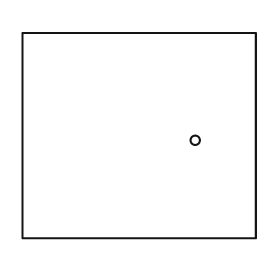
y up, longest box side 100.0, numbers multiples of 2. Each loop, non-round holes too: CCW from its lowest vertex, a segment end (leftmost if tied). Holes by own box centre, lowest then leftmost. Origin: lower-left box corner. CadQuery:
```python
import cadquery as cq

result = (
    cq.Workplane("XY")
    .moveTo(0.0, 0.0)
    .lineTo(100.0, 0.0)
    .lineTo(100.0, 88.0)
    .lineTo(0.0, 88.0)
    .close()
    .moveTo(74.0, 42.0)
    .circle(2.0)
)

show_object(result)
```